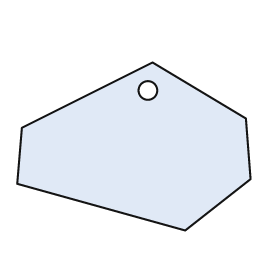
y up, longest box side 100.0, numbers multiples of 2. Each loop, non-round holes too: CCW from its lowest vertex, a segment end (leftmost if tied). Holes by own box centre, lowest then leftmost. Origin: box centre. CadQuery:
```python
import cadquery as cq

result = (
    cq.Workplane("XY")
    .moveTo(22.0, -36.0)
    .lineTo(50.0, -14.0)
    .lineTo(48.0, 12.0)
    .lineTo(8.0, 36.0)
    .lineTo(-48.0, 8.0)
    .lineTo(-50.0, -16.0)
    .close()
    .moveTo(6.0, 24.0)
    .circle(4.0)
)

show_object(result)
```